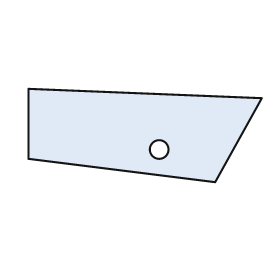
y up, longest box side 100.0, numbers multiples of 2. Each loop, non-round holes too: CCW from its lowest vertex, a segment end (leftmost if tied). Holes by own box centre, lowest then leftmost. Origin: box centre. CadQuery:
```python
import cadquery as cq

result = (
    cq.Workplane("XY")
    .moveTo(30.0, -20.0)
    .lineTo(50.0, 16.0)
    .lineTo(-50.0, 20.0)
    .lineTo(-50.0, -10.0)
    .close()
    .moveTo(6.0, -6.0)
    .circle(4.0)
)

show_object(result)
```